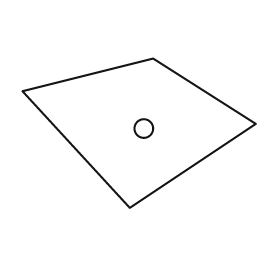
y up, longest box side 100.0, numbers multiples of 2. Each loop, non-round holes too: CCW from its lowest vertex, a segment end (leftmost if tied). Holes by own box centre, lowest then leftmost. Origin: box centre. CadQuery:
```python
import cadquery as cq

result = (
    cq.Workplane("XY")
    .moveTo(-4.0, -32.0)
    .lineTo(50.0, 4.0)
    .lineTo(6.0, 32.0)
    .lineTo(-50.0, 18.0)
    .close()
    .moveTo(2.0, 2.0)
    .circle(4.0)
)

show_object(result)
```